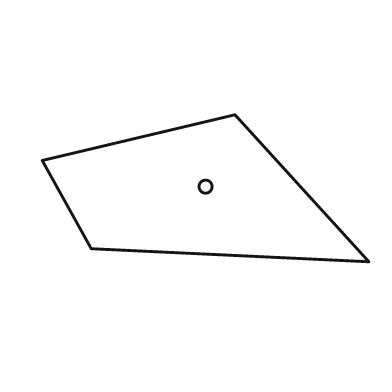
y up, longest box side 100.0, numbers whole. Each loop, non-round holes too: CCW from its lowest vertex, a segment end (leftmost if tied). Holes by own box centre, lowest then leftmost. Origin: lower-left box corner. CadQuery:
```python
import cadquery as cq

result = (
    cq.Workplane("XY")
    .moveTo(100.0, 0.0)
    .lineTo(59.0, 45.0)
    .lineTo(0.0, 31.0)
    .lineTo(15.0, 4.0)
    .close()
    .moveTo(50.0, 23.0)
    .circle(2.0)
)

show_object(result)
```